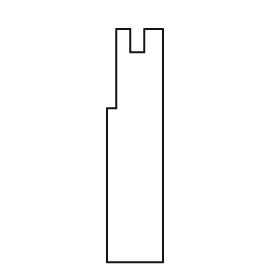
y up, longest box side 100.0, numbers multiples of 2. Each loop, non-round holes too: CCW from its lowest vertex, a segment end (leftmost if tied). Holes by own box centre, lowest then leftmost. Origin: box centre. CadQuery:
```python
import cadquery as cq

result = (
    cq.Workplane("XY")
    .moveTo(-12.0, -50.0)
    .lineTo(12.0, -50.0)
    .lineTo(12.0, 50.0)
    .lineTo(4.0, 50.0)
    .lineTo(4.0, 40.0)
    .lineTo(-2.0, 40.0)
    .lineTo(-2.0, 50.0)
    .lineTo(-8.0, 50.0)
    .lineTo(-8.0, 16.0)
    .lineTo(-12.0, 16.0)
    .close()
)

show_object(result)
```